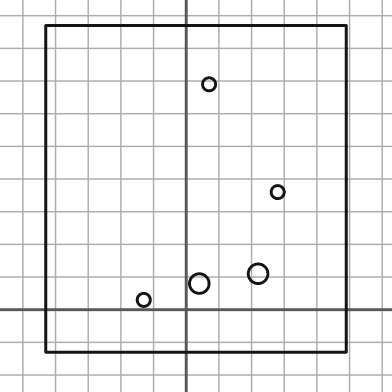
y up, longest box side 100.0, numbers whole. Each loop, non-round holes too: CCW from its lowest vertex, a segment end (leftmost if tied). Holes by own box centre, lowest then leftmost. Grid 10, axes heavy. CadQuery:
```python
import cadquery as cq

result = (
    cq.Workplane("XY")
    .moveTo(-43.0, -13.0)
    .lineTo(49.0, -13.0)
    .lineTo(49.0, 87.0)
    .lineTo(-43.0, 87.0)
    .close()
    .moveTo(-13.0, 3.0)
    .circle(2.0)
    .moveTo(4.0, 8.0)
    .circle(3.0)
    .moveTo(22.0, 11.0)
    .circle(3.0)
    .moveTo(28.0, 36.0)
    .circle(2.0)
    .moveTo(7.0, 69.0)
    .circle(2.0)
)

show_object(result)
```